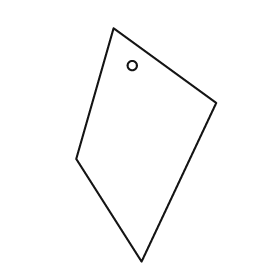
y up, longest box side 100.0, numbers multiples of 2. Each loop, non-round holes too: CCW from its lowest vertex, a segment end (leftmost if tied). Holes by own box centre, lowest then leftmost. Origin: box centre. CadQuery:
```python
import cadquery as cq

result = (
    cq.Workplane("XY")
    .moveTo(-2.0, -50.0)
    .lineTo(30.0, 18.0)
    .lineTo(-14.0, 50.0)
    .lineTo(-30.0, -6.0)
    .close()
    .moveTo(-6.0, 34.0)
    .circle(2.0)
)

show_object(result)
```